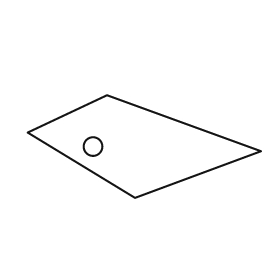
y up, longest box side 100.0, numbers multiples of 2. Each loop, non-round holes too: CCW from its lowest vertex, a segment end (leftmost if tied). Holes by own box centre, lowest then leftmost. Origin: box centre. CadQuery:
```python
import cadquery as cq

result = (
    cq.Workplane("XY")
    .moveTo(-4.0, -22.0)
    .lineTo(50.0, -2.0)
    .lineTo(-16.0, 22.0)
    .lineTo(-50.0, 6.0)
    .close()
    .moveTo(-22.0, 0.0)
    .circle(4.0)
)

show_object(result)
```